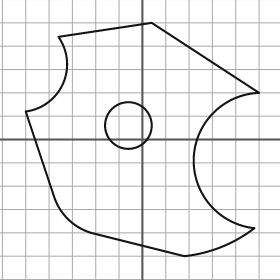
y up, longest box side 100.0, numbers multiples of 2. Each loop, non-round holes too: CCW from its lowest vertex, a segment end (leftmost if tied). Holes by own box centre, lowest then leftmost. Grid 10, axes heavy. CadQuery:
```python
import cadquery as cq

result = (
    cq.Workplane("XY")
    .moveTo(18.0, -50.0)
    .threePointArc((34.0, -46.0), (48.0, -38.0))
    .threePointArc((22.0, -8.0), (50.0, 20.0))
    .lineTo(4.0, 50.0)
    .lineTo(-36.0, 44.0)
    .threePointArc((-34.0, 24.0), (-50.0, 12.0))
    .lineTo(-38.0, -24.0)
    .threePointArc((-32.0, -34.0), (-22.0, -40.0))
    .close()
    .moveTo(-6.0, 6.0)
    .circle(10.0)
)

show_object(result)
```